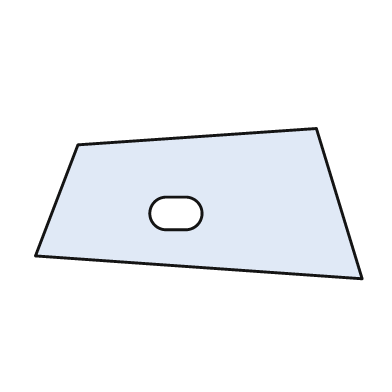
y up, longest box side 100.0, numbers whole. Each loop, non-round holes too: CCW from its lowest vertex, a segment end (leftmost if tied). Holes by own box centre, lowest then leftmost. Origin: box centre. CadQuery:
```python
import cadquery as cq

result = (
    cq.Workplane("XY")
    .moveTo(50.0, -23.0)
    .lineTo(36.0, 23.0)
    .lineTo(-37.0, 18.0)
    .lineTo(-50.0, -16.0)
    .close()
    .moveTo(-10.0, -8.0)
    .lineTo(-4.0, -8.0)
    .threePointArc((1.0, -3.0), (-4.0, 2.0))
    .lineTo(-10.0, 2.0)
    .threePointArc((-15.0, -3.0), (-10.0, -8.0))
    .close()
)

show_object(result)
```